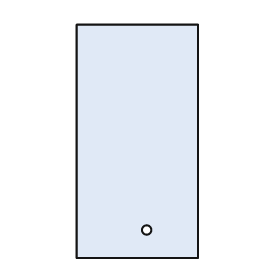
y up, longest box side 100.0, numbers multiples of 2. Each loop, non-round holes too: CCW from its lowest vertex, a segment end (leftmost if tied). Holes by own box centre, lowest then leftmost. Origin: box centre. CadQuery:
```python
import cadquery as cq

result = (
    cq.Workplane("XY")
    .moveTo(-26.0, -50.0)
    .lineTo(26.0, -50.0)
    .lineTo(26.0, 50.0)
    .lineTo(-26.0, 50.0)
    .close()
    .moveTo(4.0, -38.0)
    .circle(2.0)
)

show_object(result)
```